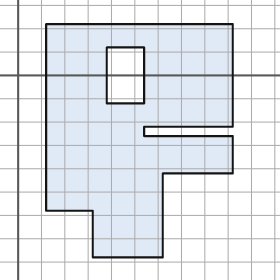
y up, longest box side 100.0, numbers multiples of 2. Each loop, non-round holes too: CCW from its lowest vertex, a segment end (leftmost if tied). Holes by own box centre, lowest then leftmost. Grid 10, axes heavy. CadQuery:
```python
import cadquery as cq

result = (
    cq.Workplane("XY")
    .moveTo(32.0, -78.0)
    .lineTo(62.0, -78.0)
    .lineTo(62.0, -42.0)
    .lineTo(92.0, -42.0)
    .lineTo(92.0, -26.0)
    .lineTo(54.0, -26.0)
    .lineTo(54.0, -22.0)
    .lineTo(92.0, -22.0)
    .lineTo(92.0, 22.0)
    .lineTo(12.0, 22.0)
    .lineTo(12.0, -58.0)
    .lineTo(32.0, -58.0)
    .close()
    .moveTo(38.0, -12.0)
    .lineTo(54.0, -12.0)
    .lineTo(54.0, 12.0)
    .lineTo(38.0, 12.0)
    .close()
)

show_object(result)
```